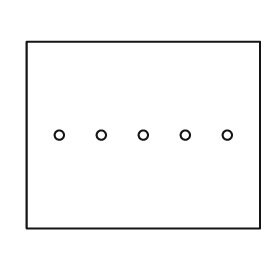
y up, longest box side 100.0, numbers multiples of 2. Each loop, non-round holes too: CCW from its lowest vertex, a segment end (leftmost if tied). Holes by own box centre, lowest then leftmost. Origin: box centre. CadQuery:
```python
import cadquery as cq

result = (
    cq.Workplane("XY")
    .moveTo(-50.0, -40.0)
    .lineTo(50.0, -40.0)
    .lineTo(50.0, 40.0)
    .lineTo(-50.0, 40.0)
    .close()
    .moveTo(-36.0, 0.0)
    .circle(2.0)
    .moveTo(-18.0, 0.0)
    .circle(2.0)
    .moveTo(0.0, 0.0)
    .circle(2.0)
    .moveTo(18.0, 0.0)
    .circle(2.0)
    .moveTo(36.0, 0.0)
    .circle(2.0)
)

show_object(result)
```